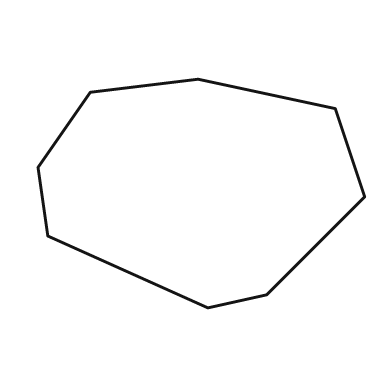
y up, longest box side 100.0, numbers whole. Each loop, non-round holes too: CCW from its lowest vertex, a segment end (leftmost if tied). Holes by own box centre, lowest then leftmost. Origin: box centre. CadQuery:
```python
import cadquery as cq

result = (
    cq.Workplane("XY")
    .moveTo(2.0, -35.0)
    .lineTo(20.0, -31.0)
    .lineTo(50.0, -1.0)
    .lineTo(41.0, 26.0)
    .lineTo(-1.0, 35.0)
    .lineTo(-34.0, 31.0)
    .lineTo(-50.0, 8.0)
    .lineTo(-47.0, -13.0)
    .close()
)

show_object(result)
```